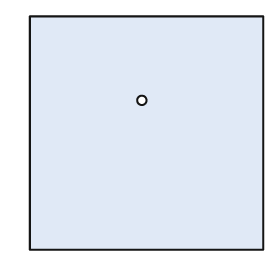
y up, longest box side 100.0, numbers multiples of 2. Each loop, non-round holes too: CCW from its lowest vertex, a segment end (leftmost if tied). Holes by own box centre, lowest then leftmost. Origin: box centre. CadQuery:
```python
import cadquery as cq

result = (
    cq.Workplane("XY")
    .moveTo(-50.0, -50.0)
    .lineTo(50.0, -50.0)
    .lineTo(50.0, 50.0)
    .lineTo(-50.0, 50.0)
    .close()
    .moveTo(-2.0, 14.0)
    .circle(2.0)
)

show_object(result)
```